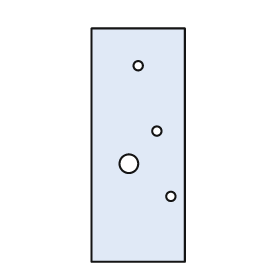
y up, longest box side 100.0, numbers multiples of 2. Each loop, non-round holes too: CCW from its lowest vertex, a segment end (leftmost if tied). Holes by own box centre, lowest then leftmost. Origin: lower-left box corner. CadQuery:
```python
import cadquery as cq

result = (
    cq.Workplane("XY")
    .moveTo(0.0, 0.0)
    .lineTo(40.0, 0.0)
    .lineTo(40.0, 100.0)
    .lineTo(0.0, 100.0)
    .close()
    .moveTo(34.0, 28.0)
    .circle(2.0)
    .moveTo(16.0, 42.0)
    .circle(4.0)
    .moveTo(28.0, 56.0)
    .circle(2.0)
    .moveTo(20.0, 84.0)
    .circle(2.0)
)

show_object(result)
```